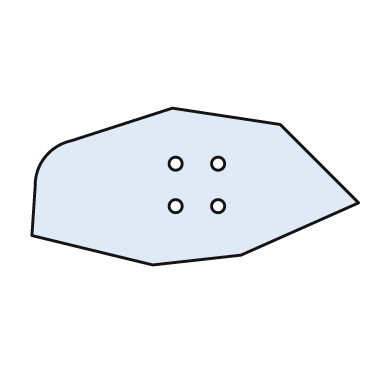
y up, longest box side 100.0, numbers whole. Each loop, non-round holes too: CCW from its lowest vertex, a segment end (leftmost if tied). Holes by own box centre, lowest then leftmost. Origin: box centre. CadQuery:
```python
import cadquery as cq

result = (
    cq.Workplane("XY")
    .moveTo(-13.0, -24.0)
    .lineTo(14.0, -21.0)
    .lineTo(50.0, -5.0)
    .lineTo(26.0, 19.0)
    .lineTo(-7.0, 24.0)
    .lineTo(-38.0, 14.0)
    .threePointArc((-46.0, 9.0), (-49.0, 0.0))
    .lineTo(-50.0, -15.0)
    .close()
    .moveTo(-6.0, -6.0)
    .circle(2.0)
    .moveTo(7.0, -6.0)
    .circle(2.0)
    .moveTo(-6.0, 7.0)
    .circle(2.0)
    .moveTo(7.0, 7.0)
    .circle(2.0)
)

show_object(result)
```